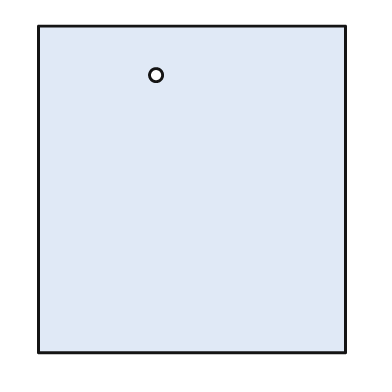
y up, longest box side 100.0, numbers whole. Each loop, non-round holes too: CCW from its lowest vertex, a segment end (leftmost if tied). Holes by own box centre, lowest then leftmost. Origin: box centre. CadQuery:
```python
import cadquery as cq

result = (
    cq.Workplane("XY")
    .moveTo(-47.0, -50.0)
    .lineTo(47.0, -50.0)
    .lineTo(47.0, 50.0)
    .lineTo(-47.0, 50.0)
    .close()
    .moveTo(-11.0, 35.0)
    .circle(2.0)
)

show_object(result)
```